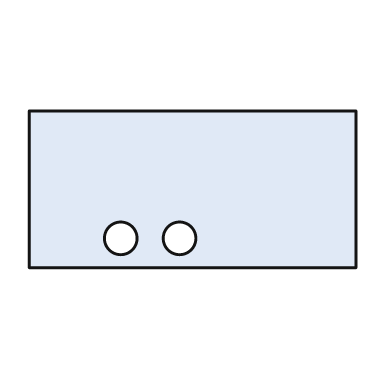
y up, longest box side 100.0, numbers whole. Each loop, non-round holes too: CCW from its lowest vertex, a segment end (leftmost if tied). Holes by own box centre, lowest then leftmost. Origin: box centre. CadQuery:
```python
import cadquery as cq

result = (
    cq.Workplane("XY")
    .moveTo(-50.0, -24.0)
    .lineTo(50.0, -24.0)
    .lineTo(50.0, 24.0)
    .lineTo(-50.0, 24.0)
    .close()
    .moveTo(-22.0, -15.0)
    .circle(5.0)
    .moveTo(-4.0, -15.0)
    .circle(5.0)
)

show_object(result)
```